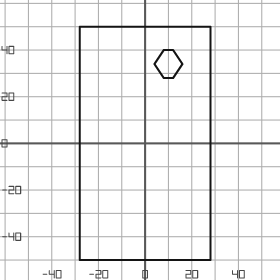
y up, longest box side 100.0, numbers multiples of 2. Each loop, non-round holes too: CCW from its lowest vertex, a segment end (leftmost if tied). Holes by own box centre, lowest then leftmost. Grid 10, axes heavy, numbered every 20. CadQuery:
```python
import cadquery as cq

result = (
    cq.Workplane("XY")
    .moveTo(-28.0, -50.0)
    .lineTo(28.0, -50.0)
    .lineTo(28.0, 50.0)
    .lineTo(-28.0, 50.0)
    .close()
    .moveTo(8.0, 28.0)
    .lineTo(12.0, 28.0)
    .lineTo(16.0, 34.0)
    .lineTo(12.0, 40.0)
    .lineTo(8.0, 40.0)
    .lineTo(4.0, 34.0)
    .close()
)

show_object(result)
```